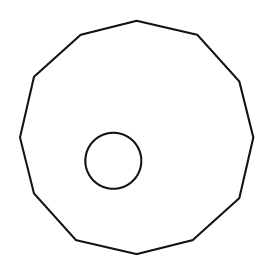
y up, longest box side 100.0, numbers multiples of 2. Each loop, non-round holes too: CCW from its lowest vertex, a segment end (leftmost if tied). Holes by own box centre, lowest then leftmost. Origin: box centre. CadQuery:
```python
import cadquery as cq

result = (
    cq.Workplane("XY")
    .moveTo(0.0, -50.0)
    .lineTo(24.0, -44.0)
    .lineTo(44.0, -26.0)
    .lineTo(50.0, 0.0)
    .lineTo(44.0, 24.0)
    .lineTo(26.0, 44.0)
    .lineTo(0.0, 50.0)
    .lineTo(-24.0, 44.0)
    .lineTo(-44.0, 26.0)
    .lineTo(-50.0, 0.0)
    .lineTo(-44.0, -24.0)
    .lineTo(-26.0, -44.0)
    .close()
    .moveTo(-10.0, -10.0)
    .circle(12.0)
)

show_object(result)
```